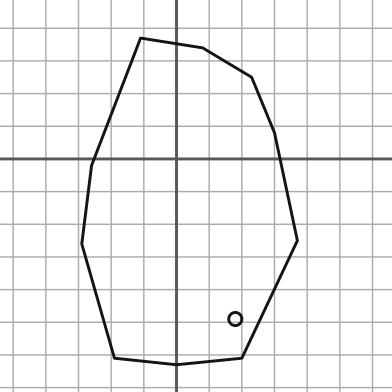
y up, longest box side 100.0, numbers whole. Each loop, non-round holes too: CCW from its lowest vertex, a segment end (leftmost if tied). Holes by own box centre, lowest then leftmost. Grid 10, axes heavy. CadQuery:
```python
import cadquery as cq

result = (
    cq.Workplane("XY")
    .moveTo(0.0, -63.0)
    .lineTo(20.0, -61.0)
    .lineTo(37.0, -25.0)
    .lineTo(30.0, 8.0)
    .lineTo(23.0, 25.0)
    .lineTo(8.0, 34.0)
    .lineTo(-11.0, 37.0)
    .lineTo(-26.0, -2.0)
    .lineTo(-29.0, -26.0)
    .lineTo(-19.0, -61.0)
    .close()
    .moveTo(18.0, -49.0)
    .circle(2.0)
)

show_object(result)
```